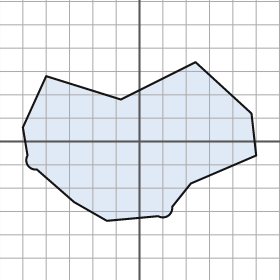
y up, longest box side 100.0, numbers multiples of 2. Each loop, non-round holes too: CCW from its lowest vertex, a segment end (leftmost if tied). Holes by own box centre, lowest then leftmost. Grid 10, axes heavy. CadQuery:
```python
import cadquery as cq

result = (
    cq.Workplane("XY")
    .moveTo(-14.0, -34.0)
    .lineTo(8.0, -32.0)
    .threePointArc((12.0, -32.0), (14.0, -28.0))
    .lineTo(22.0, -18.0)
    .lineTo(50.0, -6.0)
    .lineTo(48.0, 12.0)
    .lineTo(24.0, 34.0)
    .lineTo(-8.0, 18.0)
    .lineTo(-40.0, 28.0)
    .lineTo(-50.0, 6.0)
    .lineTo(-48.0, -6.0)
    .threePointArc((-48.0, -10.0), (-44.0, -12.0))
    .lineTo(-28.0, -26.0)
    .close()
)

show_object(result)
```